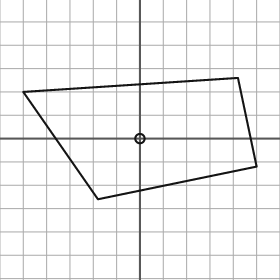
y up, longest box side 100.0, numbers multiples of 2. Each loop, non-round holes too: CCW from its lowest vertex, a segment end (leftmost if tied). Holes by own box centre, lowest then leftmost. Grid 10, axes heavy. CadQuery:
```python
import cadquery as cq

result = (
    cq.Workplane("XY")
    .moveTo(-18.0, -26.0)
    .lineTo(50.0, -12.0)
    .lineTo(42.0, 26.0)
    .lineTo(-50.0, 20.0)
    .close()
    .moveTo(0.0, 0.0)
    .circle(2.0)
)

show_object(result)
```